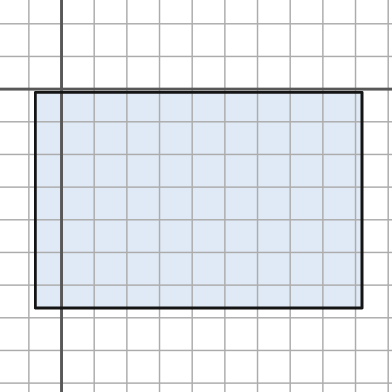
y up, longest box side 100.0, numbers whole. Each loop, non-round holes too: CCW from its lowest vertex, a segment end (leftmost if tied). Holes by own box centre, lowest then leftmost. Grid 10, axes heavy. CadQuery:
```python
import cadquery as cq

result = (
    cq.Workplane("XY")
    .moveTo(-8.0, -67.0)
    .lineTo(92.0, -67.0)
    .lineTo(92.0, -1.0)
    .lineTo(-8.0, -1.0)
    .close()
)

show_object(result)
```